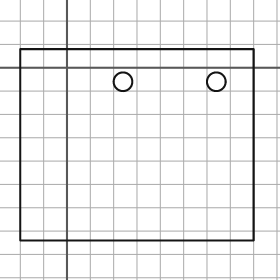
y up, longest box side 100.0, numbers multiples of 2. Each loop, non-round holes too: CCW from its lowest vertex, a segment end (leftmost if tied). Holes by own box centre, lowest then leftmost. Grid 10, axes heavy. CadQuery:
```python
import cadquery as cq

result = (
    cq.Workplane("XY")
    .moveTo(-20.0, -74.0)
    .lineTo(80.0, -74.0)
    .lineTo(80.0, 8.0)
    .lineTo(-20.0, 8.0)
    .close()
    .moveTo(24.0, -6.0)
    .circle(4.0)
    .moveTo(64.0, -6.0)
    .circle(4.0)
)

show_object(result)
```